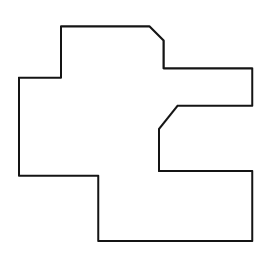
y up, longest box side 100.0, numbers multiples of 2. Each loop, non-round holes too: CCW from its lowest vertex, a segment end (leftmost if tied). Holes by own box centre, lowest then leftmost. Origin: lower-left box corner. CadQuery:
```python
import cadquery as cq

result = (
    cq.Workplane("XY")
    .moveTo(34.0, 0.0)
    .lineTo(100.0, 0.0)
    .lineTo(100.0, 30.0)
    .lineTo(60.0, 30.0)
    .lineTo(60.0, 48.0)
    .lineTo(68.0, 58.0)
    .lineTo(100.0, 58.0)
    .lineTo(100.0, 74.0)
    .lineTo(62.0, 74.0)
    .lineTo(62.0, 86.0)
    .lineTo(56.0, 92.0)
    .lineTo(18.0, 92.0)
    .lineTo(18.0, 70.0)
    .lineTo(0.0, 70.0)
    .lineTo(0.0, 28.0)
    .lineTo(34.0, 28.0)
    .close()
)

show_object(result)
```